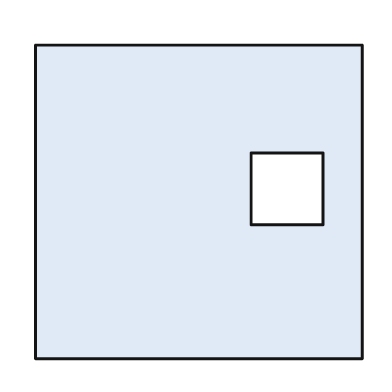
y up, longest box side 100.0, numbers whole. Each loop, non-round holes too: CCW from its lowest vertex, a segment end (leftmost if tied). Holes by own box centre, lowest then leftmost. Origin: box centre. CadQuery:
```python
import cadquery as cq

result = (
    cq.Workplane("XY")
    .moveTo(-50.0, -48.0)
    .lineTo(50.0, -48.0)
    .lineTo(50.0, 48.0)
    .lineTo(-50.0, 48.0)
    .close()
    .moveTo(16.0, -7.0)
    .lineTo(38.0, -7.0)
    .lineTo(38.0, 15.0)
    .lineTo(16.0, 15.0)
    .close()
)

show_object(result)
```